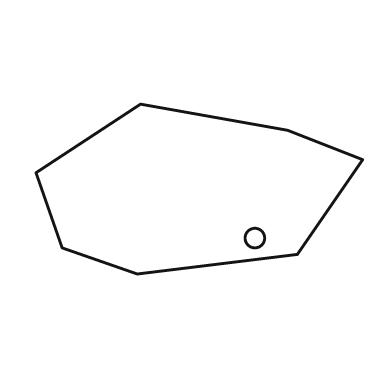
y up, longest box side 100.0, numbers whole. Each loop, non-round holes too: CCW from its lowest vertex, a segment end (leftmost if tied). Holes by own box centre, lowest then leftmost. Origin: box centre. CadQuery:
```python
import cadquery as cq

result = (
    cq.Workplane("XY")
    .moveTo(-19.0, -26.0)
    .lineTo(30.0, -20.0)
    .lineTo(50.0, 9.0)
    .lineTo(27.0, 18.0)
    .lineTo(-18.0, 26.0)
    .lineTo(-50.0, 5.0)
    .lineTo(-42.0, -18.0)
    .close()
    .moveTo(17.0, -15.0)
    .circle(3.0)
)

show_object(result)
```